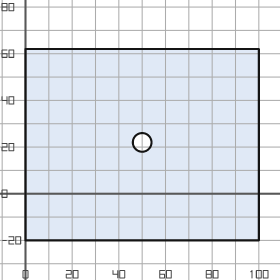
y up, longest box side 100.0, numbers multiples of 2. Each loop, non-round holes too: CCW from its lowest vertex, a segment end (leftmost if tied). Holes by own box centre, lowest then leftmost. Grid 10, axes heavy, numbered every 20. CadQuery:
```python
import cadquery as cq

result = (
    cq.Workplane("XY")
    .moveTo(0.0, -20.0)
    .lineTo(100.0, -20.0)
    .lineTo(100.0, 62.0)
    .lineTo(0.0, 62.0)
    .close()
    .moveTo(50.0, 22.0)
    .circle(4.0)
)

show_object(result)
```